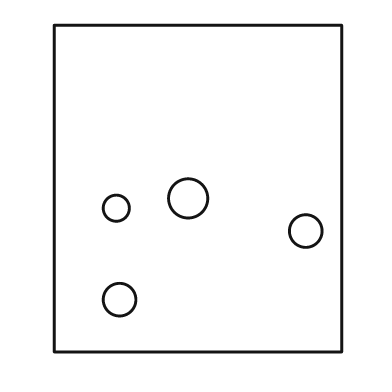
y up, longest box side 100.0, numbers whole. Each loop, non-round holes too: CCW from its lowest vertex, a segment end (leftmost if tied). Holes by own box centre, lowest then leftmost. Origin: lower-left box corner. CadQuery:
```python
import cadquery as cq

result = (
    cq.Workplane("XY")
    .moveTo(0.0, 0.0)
    .lineTo(88.0, 0.0)
    .lineTo(88.0, 100.0)
    .lineTo(0.0, 100.0)
    .close()
    .moveTo(20.0, 16.0)
    .circle(5.0)
    .moveTo(77.0, 37.0)
    .circle(5.0)
    .moveTo(19.0, 44.0)
    .circle(4.0)
    .moveTo(41.0, 47.0)
    .circle(6.0)
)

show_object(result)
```